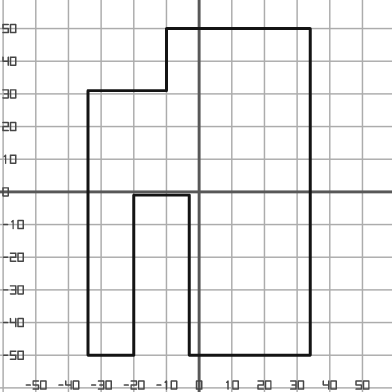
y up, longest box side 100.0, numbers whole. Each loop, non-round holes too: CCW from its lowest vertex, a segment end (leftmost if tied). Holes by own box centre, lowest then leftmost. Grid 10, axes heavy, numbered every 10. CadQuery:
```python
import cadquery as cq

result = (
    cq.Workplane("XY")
    .moveTo(-34.0, -50.0)
    .lineTo(-20.0, -50.0)
    .lineTo(-20.0, -1.0)
    .lineTo(-3.0, -1.0)
    .lineTo(-3.0, -50.0)
    .lineTo(34.0, -50.0)
    .lineTo(34.0, 50.0)
    .lineTo(-10.0, 50.0)
    .lineTo(-10.0, 31.0)
    .lineTo(-34.0, 31.0)
    .close()
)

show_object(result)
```